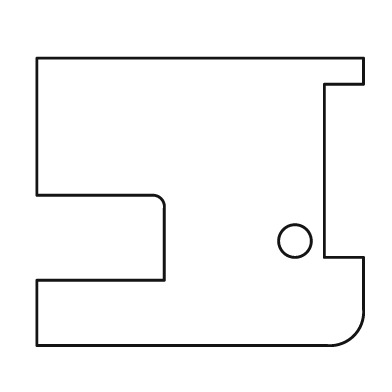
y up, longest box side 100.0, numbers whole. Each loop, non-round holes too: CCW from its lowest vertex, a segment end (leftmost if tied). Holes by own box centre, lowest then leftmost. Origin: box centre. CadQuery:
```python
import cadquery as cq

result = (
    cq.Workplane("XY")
    .moveTo(-50.0, -44.0)
    .lineTo(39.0, -44.0)
    .threePointArc((47.0, -41.0), (50.0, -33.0))
    .lineTo(50.0, -17.0)
    .lineTo(38.0, -17.0)
    .lineTo(38.0, 36.0)
    .lineTo(50.0, 36.0)
    .lineTo(50.0, 44.0)
    .lineTo(-50.0, 44.0)
    .lineTo(-50.0, 2.0)
    .lineTo(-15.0, 2.0)
    .threePointArc((-12.0, 1.0), (-11.0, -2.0))
    .lineTo(-11.0, -24.0)
    .lineTo(-50.0, -24.0)
    .close()
    .moveTo(29.0, -12.0)
    .circle(5.0)
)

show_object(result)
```